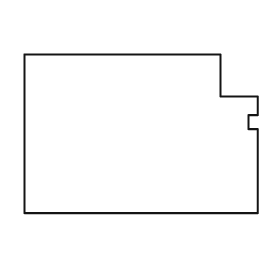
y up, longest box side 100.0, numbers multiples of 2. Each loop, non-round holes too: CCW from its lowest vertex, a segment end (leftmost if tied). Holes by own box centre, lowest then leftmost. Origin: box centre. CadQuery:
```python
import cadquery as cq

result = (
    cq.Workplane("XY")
    .moveTo(-50.0, -34.0)
    .lineTo(50.0, -34.0)
    .lineTo(50.0, 2.0)
    .lineTo(46.0, 2.0)
    .lineTo(46.0, 8.0)
    .lineTo(50.0, 8.0)
    .lineTo(50.0, 16.0)
    .lineTo(34.0, 16.0)
    .lineTo(34.0, 34.0)
    .lineTo(-50.0, 34.0)
    .close()
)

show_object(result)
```